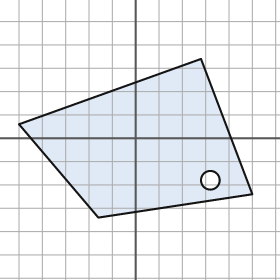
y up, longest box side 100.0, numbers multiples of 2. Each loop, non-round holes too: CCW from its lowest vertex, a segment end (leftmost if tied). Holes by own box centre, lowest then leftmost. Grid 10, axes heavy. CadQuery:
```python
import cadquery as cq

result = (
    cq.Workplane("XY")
    .moveTo(-16.0, -34.0)
    .lineTo(50.0, -24.0)
    .lineTo(28.0, 34.0)
    .lineTo(-50.0, 6.0)
    .close()
    .moveTo(32.0, -18.0)
    .circle(4.0)
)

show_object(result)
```